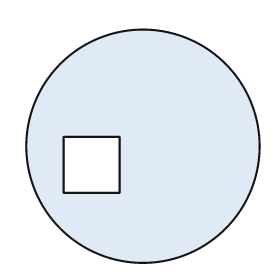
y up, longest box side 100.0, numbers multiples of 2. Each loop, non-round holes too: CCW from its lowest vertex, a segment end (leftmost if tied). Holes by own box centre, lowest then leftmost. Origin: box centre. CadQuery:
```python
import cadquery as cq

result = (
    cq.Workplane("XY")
    .moveTo(0.0, 0.0)
    .circle(50.0)
    .moveTo(-34.0, -20.0)
    .lineTo(-10.0, -20.0)
    .lineTo(-10.0, 4.0)
    .lineTo(-34.0, 4.0)
    .close()
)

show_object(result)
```